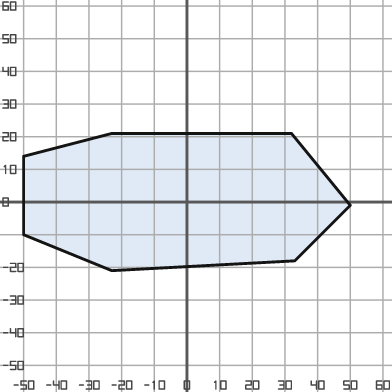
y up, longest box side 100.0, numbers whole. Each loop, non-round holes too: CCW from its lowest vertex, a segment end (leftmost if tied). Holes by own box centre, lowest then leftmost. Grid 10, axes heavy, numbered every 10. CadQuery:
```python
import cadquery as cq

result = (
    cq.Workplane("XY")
    .moveTo(-23.0, -21.0)
    .lineTo(33.0, -18.0)
    .lineTo(50.0, -1.0)
    .lineTo(32.0, 21.0)
    .lineTo(-23.0, 21.0)
    .lineTo(-50.0, 14.0)
    .lineTo(-50.0, -10.0)
    .close()
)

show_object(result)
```